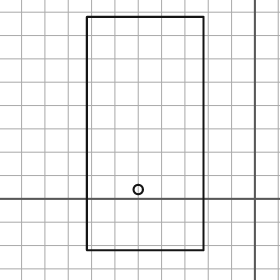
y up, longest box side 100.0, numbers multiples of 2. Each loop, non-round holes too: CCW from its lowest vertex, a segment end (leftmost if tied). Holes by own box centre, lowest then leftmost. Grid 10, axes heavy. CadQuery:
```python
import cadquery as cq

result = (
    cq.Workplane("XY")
    .moveTo(-72.0, -22.0)
    .lineTo(-22.0, -22.0)
    .lineTo(-22.0, 78.0)
    .lineTo(-72.0, 78.0)
    .close()
    .moveTo(-50.0, 4.0)
    .circle(2.0)
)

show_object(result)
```